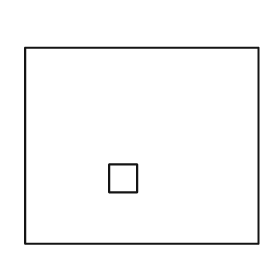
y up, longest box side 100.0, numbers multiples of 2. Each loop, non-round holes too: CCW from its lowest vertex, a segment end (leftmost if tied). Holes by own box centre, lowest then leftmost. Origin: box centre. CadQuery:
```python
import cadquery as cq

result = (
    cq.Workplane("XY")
    .moveTo(-50.0, -42.0)
    .lineTo(50.0, -42.0)
    .lineTo(50.0, 42.0)
    .lineTo(-50.0, 42.0)
    .close()
    .moveTo(-14.0, -20.0)
    .lineTo(-2.0, -20.0)
    .lineTo(-2.0, -8.0)
    .lineTo(-14.0, -8.0)
    .close()
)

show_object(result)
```